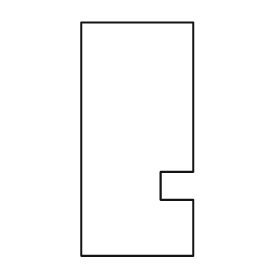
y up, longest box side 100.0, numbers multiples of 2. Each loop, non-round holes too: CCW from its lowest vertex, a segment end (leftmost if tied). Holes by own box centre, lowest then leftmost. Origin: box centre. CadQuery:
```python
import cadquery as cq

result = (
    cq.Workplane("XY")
    .moveTo(-24.0, -50.0)
    .lineTo(24.0, -50.0)
    .lineTo(24.0, -26.0)
    .lineTo(10.0, -26.0)
    .lineTo(10.0, -14.0)
    .lineTo(24.0, -14.0)
    .lineTo(24.0, 50.0)
    .lineTo(-24.0, 50.0)
    .close()
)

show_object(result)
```